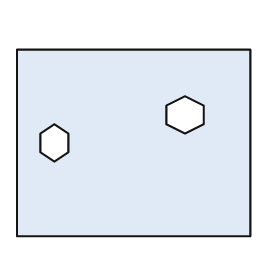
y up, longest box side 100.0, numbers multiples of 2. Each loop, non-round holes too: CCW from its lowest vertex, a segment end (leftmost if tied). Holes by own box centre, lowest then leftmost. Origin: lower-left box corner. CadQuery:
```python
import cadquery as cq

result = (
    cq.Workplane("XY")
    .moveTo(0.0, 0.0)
    .lineTo(100.0, 0.0)
    .lineTo(100.0, 80.0)
    .lineTo(0.0, 80.0)
    .close()
    .moveTo(16.0, 32.0)
    .lineTo(22.0, 36.0)
    .lineTo(22.0, 44.0)
    .lineTo(16.0, 48.0)
    .lineTo(10.0, 44.0)
    .lineTo(10.0, 36.0)
    .close()
    .moveTo(72.0, 44.0)
    .lineTo(80.0, 48.0)
    .lineTo(80.0, 56.0)
    .lineTo(72.0, 60.0)
    .lineTo(64.0, 56.0)
    .lineTo(64.0, 48.0)
    .close()
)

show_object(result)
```